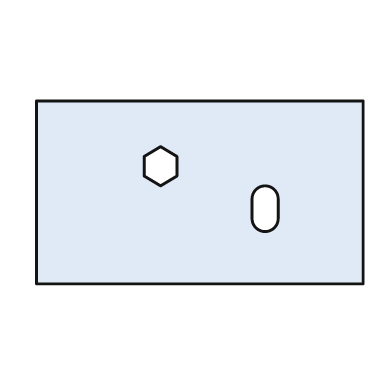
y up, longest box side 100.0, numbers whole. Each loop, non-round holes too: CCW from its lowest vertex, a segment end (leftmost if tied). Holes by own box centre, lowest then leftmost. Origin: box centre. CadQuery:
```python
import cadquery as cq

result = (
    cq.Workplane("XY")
    .moveTo(-50.0, -28.0)
    .lineTo(50.0, -28.0)
    .lineTo(50.0, 28.0)
    .lineTo(-50.0, 28.0)
    .close()
    .moveTo(16.0, -8.0)
    .threePointArc((20.0, -12.0), (24.0, -8.0))
    .lineTo(24.0, -2.0)
    .threePointArc((20.0, 2.0), (16.0, -2.0))
    .close()
    .moveTo(-12.0, 2.0)
    .lineTo(-7.0, 5.0)
    .lineTo(-7.0, 11.0)
    .lineTo(-12.0, 14.0)
    .lineTo(-17.0, 11.0)
    .lineTo(-17.0, 5.0)
    .close()
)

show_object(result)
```